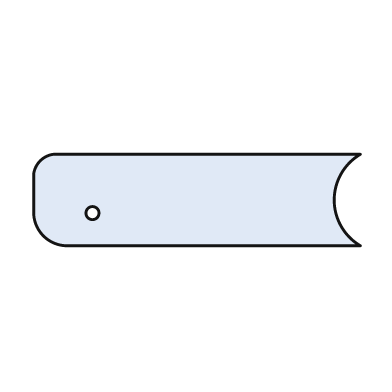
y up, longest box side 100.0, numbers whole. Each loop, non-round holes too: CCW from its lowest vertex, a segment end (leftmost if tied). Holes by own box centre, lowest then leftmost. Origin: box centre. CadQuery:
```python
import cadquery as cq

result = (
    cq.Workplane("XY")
    .moveTo(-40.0, -14.0)
    .lineTo(50.0, -14.0)
    .threePointArc((42.0, 0.0), (50.0, 14.0))
    .lineTo(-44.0, 14.0)
    .threePointArc((-48.0, 12.0), (-50.0, 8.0))
    .lineTo(-50.0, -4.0)
    .threePointArc((-47.0, -11.0), (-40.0, -14.0))
    .close()
    .moveTo(-32.0, -4.0)
    .circle(2.0)
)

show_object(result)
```